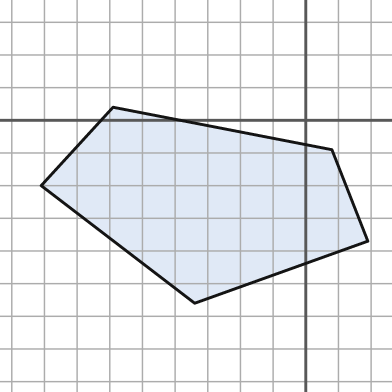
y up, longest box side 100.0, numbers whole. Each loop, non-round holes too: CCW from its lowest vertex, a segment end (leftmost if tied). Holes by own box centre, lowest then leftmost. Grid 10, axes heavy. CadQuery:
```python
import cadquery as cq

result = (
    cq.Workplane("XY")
    .moveTo(-34.0, -56.0)
    .lineTo(19.0, -37.0)
    .lineTo(8.0, -9.0)
    .lineTo(-59.0, 4.0)
    .lineTo(-81.0, -20.0)
    .close()
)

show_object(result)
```